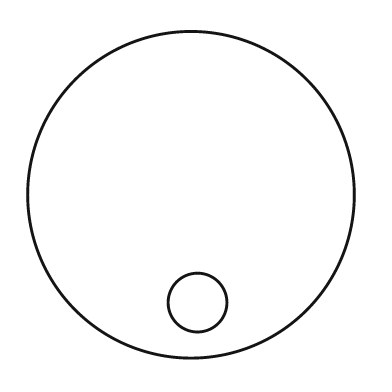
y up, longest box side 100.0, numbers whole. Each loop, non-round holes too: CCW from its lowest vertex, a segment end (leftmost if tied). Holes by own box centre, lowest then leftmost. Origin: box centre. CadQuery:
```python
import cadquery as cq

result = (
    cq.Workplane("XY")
    .moveTo(0.0, 0.0)
    .circle(50.0)
    .moveTo(2.0, -33.0)
    .circle(9.0)
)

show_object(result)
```